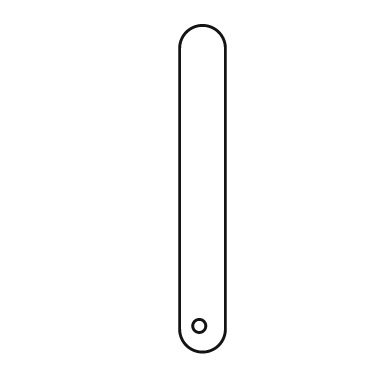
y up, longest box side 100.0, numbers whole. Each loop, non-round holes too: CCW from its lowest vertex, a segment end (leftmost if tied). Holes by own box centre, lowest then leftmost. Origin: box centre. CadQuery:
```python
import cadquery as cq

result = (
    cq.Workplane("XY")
    .moveTo(-7.0, -43.0)
    .threePointArc((0.0, -50.0), (7.0, -43.0))
    .lineTo(7.0, 43.0)
    .threePointArc((0.0, 50.0), (-7.0, 43.0))
    .close()
    .moveTo(-1.0, -42.0)
    .circle(2.0)
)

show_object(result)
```